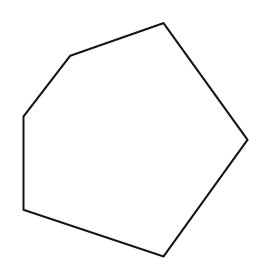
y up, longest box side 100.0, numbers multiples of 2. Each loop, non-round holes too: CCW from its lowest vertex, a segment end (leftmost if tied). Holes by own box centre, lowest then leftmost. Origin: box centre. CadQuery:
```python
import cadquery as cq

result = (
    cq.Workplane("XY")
    .moveTo(12.0, -50.0)
    .lineTo(48.0, 0.0)
    .lineTo(12.0, 50.0)
    .lineTo(-28.0, 36.0)
    .lineTo(-48.0, 10.0)
    .lineTo(-48.0, -30.0)
    .close()
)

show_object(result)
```